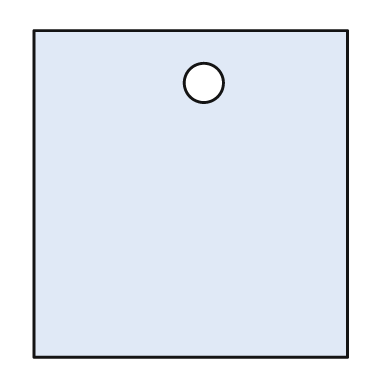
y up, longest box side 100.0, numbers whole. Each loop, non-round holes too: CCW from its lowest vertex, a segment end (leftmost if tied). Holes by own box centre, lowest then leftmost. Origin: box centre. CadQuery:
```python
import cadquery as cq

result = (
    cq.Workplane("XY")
    .moveTo(-48.0, -50.0)
    .lineTo(48.0, -50.0)
    .lineTo(48.0, 50.0)
    .lineTo(-48.0, 50.0)
    .close()
    .moveTo(4.0, 34.0)
    .circle(6.0)
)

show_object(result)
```